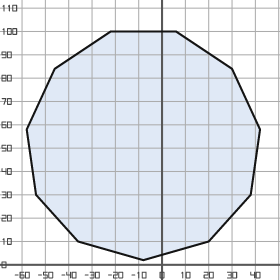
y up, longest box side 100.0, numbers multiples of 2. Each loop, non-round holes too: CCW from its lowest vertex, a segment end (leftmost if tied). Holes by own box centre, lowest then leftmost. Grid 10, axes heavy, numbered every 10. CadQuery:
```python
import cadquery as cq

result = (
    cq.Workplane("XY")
    .moveTo(-8.0, 2.0)
    .lineTo(20.0, 10.0)
    .lineTo(38.0, 30.0)
    .lineTo(42.0, 58.0)
    .lineTo(30.0, 84.0)
    .lineTo(6.0, 100.0)
    .lineTo(-22.0, 100.0)
    .lineTo(-46.0, 84.0)
    .lineTo(-58.0, 58.0)
    .lineTo(-54.0, 30.0)
    .lineTo(-36.0, 10.0)
    .close()
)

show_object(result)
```